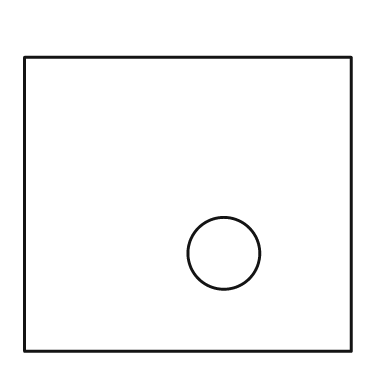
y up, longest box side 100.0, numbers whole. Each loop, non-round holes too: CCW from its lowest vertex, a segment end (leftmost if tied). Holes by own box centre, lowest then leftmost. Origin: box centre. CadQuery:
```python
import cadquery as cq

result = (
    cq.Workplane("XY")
    .moveTo(-50.0, -45.0)
    .lineTo(50.0, -45.0)
    .lineTo(50.0, 45.0)
    .lineTo(-50.0, 45.0)
    .close()
    .moveTo(11.0, -15.0)
    .circle(11.0)
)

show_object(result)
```